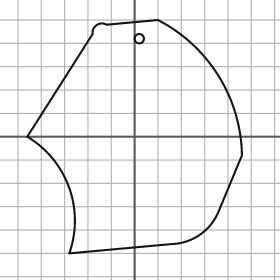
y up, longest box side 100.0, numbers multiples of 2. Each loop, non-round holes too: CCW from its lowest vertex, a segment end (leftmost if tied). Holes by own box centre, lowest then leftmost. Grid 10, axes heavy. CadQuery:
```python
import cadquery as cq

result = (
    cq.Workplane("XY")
    .moveTo(-28.0, -50.0)
    .lineTo(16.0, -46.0)
    .threePointArc((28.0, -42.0), (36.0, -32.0))
    .lineTo(46.0, -8.0)
    .threePointArc((36.0, 26.0), (10.0, 50.0))
    .lineTo(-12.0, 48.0)
    .threePointArc((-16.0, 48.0), (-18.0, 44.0))
    .lineTo(-46.0, 0.0)
    .threePointArc((-28.0, -22.0), (-28.0, -50.0))
    .close()
    .moveTo(2.0, 42.0)
    .circle(2.0)
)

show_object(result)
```